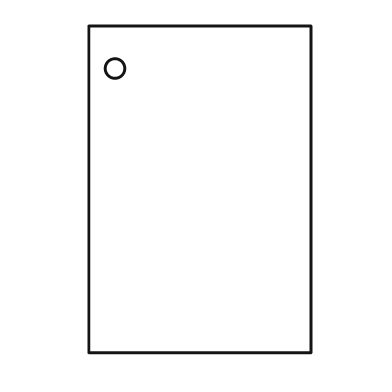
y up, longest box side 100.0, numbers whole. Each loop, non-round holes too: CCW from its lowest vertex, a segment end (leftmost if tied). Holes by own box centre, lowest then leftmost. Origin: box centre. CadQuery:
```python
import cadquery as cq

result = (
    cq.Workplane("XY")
    .moveTo(-34.0, -50.0)
    .lineTo(34.0, -50.0)
    .lineTo(34.0, 50.0)
    .lineTo(-34.0, 50.0)
    .close()
    .moveTo(-26.0, 37.0)
    .circle(3.0)
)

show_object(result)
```